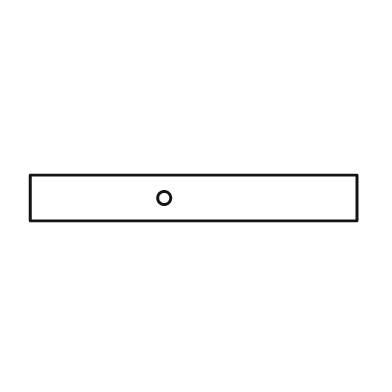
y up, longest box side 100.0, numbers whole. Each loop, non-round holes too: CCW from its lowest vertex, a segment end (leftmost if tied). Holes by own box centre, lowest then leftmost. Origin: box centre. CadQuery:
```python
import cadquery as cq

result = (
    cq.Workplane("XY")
    .moveTo(-50.0, -7.0)
    .lineTo(50.0, -7.0)
    .lineTo(50.0, 7.0)
    .lineTo(-50.0, 7.0)
    .close()
    .moveTo(-9.0, 0.0)
    .circle(2.0)
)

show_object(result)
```